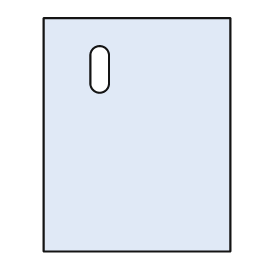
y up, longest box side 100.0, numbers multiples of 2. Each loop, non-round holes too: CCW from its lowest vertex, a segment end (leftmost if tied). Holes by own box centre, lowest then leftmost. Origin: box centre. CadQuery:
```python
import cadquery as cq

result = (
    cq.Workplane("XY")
    .moveTo(-40.0, -50.0)
    .lineTo(40.0, -50.0)
    .lineTo(40.0, 50.0)
    .lineTo(-40.0, 50.0)
    .close()
    .moveTo(-20.0, 22.0)
    .threePointArc((-16.0, 18.0), (-12.0, 22.0))
    .lineTo(-12.0, 34.0)
    .threePointArc((-16.0, 38.0), (-20.0, 34.0))
    .close()
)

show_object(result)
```